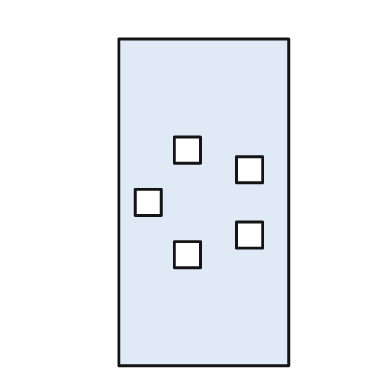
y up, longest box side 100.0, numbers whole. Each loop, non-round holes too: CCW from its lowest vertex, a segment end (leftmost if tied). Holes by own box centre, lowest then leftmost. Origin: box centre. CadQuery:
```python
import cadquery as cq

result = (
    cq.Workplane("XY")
    .moveTo(-26.0, -50.0)
    .lineTo(26.0, -50.0)
    .lineTo(26.0, 50.0)
    .lineTo(-26.0, 50.0)
    .close()
    .moveTo(-9.0, -20.0)
    .lineTo(-1.0, -20.0)
    .lineTo(-1.0, -12.0)
    .lineTo(-9.0, -12.0)
    .close()
    .moveTo(10.0, -14.0)
    .lineTo(18.0, -14.0)
    .lineTo(18.0, -6.0)
    .lineTo(10.0, -6.0)
    .close()
    .moveTo(-21.0, -4.0)
    .lineTo(-13.0, -4.0)
    .lineTo(-13.0, 4.0)
    .lineTo(-21.0, 4.0)
    .close()
    .moveTo(10.0, 6.0)
    .lineTo(18.0, 6.0)
    .lineTo(18.0, 14.0)
    .lineTo(10.0, 14.0)
    .close()
    .moveTo(-9.0, 12.0)
    .lineTo(-1.0, 12.0)
    .lineTo(-1.0, 20.0)
    .lineTo(-9.0, 20.0)
    .close()
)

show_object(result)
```